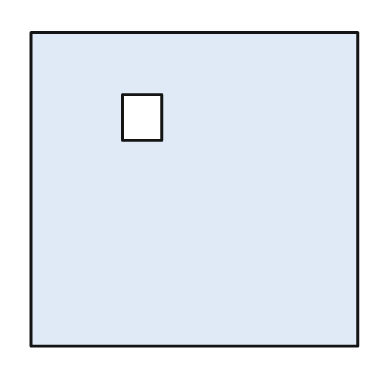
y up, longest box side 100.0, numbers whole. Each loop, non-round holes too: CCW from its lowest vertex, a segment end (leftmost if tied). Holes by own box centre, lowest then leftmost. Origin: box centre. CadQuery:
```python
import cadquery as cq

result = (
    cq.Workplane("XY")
    .moveTo(-50.0, -48.0)
    .lineTo(50.0, -48.0)
    .lineTo(50.0, 48.0)
    .lineTo(-50.0, 48.0)
    .close()
    .moveTo(-22.0, 15.0)
    .lineTo(-10.0, 15.0)
    .lineTo(-10.0, 29.0)
    .lineTo(-22.0, 29.0)
    .close()
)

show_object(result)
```